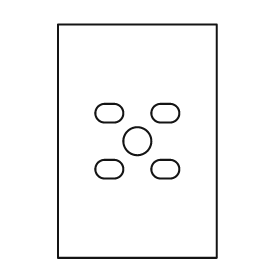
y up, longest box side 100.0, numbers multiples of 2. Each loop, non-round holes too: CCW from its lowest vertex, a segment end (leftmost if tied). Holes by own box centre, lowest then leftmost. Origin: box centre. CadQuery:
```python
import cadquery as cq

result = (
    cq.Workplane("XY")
    .moveTo(-34.0, -50.0)
    .lineTo(34.0, -50.0)
    .lineTo(34.0, 50.0)
    .lineTo(-34.0, 50.0)
    .close()
    .moveTo(-14.0, -16.0)
    .lineTo(-10.0, -16.0)
    .threePointArc((-6.0, -12.0), (-10.0, -8.0))
    .lineTo(-14.0, -8.0)
    .threePointArc((-18.0, -12.0), (-14.0, -16.0))
    .close()
    .moveTo(10.0, -16.0)
    .lineTo(14.0, -16.0)
    .threePointArc((18.0, -12.0), (14.0, -8.0))
    .lineTo(10.0, -8.0)
    .threePointArc((6.0, -12.0), (10.0, -16.0))
    .close()
    .moveTo(0.0, 0.0)
    .circle(6.0)
    .moveTo(-14.0, 8.0)
    .lineTo(-10.0, 8.0)
    .threePointArc((-6.0, 12.0), (-10.0, 16.0))
    .lineTo(-14.0, 16.0)
    .threePointArc((-18.0, 12.0), (-14.0, 8.0))
    .close()
    .moveTo(10.0, 8.0)
    .lineTo(14.0, 8.0)
    .threePointArc((18.0, 12.0), (14.0, 16.0))
    .lineTo(10.0, 16.0)
    .threePointArc((6.0, 12.0), (10.0, 8.0))
    .close()
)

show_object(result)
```